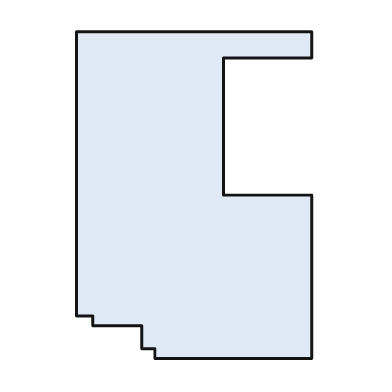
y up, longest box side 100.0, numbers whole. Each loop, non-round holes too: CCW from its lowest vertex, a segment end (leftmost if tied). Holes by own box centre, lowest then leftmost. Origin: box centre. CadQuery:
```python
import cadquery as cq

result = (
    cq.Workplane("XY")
    .moveTo(-12.0, -50.0)
    .lineTo(36.0, -50.0)
    .lineTo(36.0, 0.0)
    .lineTo(9.0, 0.0)
    .lineTo(9.0, 42.0)
    .lineTo(36.0, 42.0)
    .lineTo(36.0, 50.0)
    .lineTo(-36.0, 50.0)
    .lineTo(-36.0, -37.0)
    .lineTo(-31.0, -37.0)
    .lineTo(-31.0, -40.0)
    .lineTo(-16.0, -40.0)
    .lineTo(-16.0, -47.0)
    .lineTo(-12.0, -47.0)
    .close()
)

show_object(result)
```